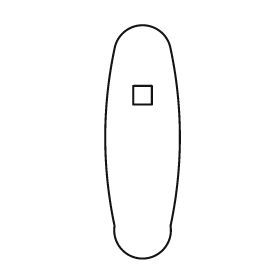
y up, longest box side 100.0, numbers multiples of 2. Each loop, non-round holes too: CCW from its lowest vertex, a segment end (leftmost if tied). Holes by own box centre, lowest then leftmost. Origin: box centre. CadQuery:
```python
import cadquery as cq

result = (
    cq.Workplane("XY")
    .moveTo(-12.0, -36.0)
    .threePointArc((0.0, -50.0), (12.0, -36.0))
    .threePointArc((16.0, 2.0), (12.0, 40.0))
    .threePointArc((0.0, 50.0), (-12.0, 40.0))
    .threePointArc((-16.0, 2.0), (-12.0, -36.0))
    .close()
    .moveTo(-4.0, 16.0)
    .lineTo(4.0, 16.0)
    .lineTo(4.0, 24.0)
    .lineTo(-4.0, 24.0)
    .close()
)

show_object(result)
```